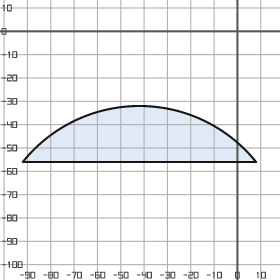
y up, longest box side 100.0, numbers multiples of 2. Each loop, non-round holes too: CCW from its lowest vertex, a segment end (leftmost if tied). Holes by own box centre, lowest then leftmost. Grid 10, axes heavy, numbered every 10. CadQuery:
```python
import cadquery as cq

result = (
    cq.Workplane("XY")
    .moveTo(-92.0, -56.0)
    .lineTo(8.0, -56.0)
    .threePointArc((-42.0, -32.0), (-92.0, -56.0))
    .close()
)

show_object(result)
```